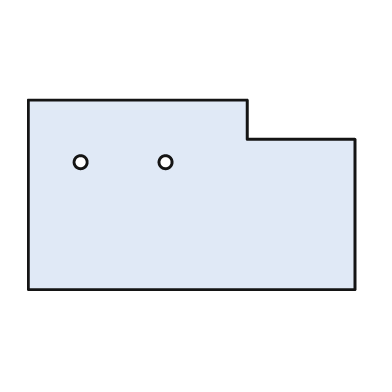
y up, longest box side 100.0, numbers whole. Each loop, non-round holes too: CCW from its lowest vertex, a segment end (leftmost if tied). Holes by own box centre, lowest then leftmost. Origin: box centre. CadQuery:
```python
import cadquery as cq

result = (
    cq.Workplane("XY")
    .moveTo(-50.0, -29.0)
    .lineTo(50.0, -29.0)
    .lineTo(50.0, 17.0)
    .lineTo(17.0, 17.0)
    .lineTo(17.0, 29.0)
    .lineTo(-50.0, 29.0)
    .close()
    .moveTo(-34.0, 10.0)
    .circle(2.0)
    .moveTo(-8.0, 10.0)
    .circle(2.0)
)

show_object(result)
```